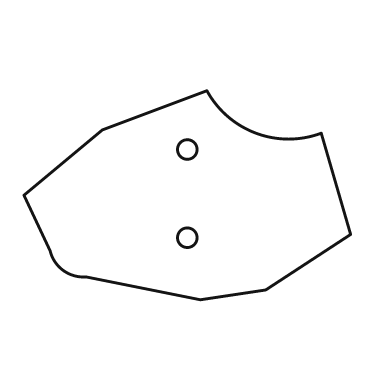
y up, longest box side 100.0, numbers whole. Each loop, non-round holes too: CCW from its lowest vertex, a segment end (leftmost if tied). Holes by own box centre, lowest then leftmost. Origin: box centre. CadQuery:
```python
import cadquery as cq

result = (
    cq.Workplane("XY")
    .moveTo(4.0, -32.0)
    .lineTo(24.0, -29.0)
    .lineTo(50.0, -12.0)
    .lineTo(41.0, 19.0)
    .threePointArc((21.0, 19.0), (6.0, 32.0))
    .lineTo(-26.0, 20.0)
    .lineTo(-50.0, 0.0)
    .lineTo(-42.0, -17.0)
    .threePointArc((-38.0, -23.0), (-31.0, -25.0))
    .close()
    .moveTo(0.0, -13.0)
    .circle(3.0)
    .moveTo(0.0, 14.0)
    .circle(3.0)
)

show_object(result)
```